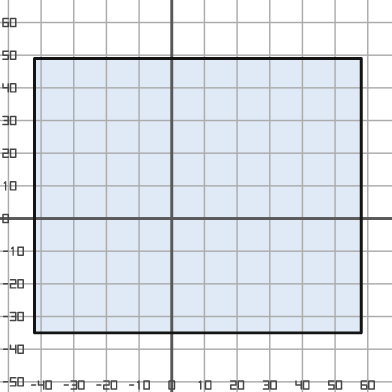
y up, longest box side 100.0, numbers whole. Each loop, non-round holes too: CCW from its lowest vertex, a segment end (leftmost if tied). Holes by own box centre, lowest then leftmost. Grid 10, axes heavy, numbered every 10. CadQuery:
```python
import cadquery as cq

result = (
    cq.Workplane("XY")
    .moveTo(-42.0, -35.0)
    .lineTo(58.0, -35.0)
    .lineTo(58.0, 49.0)
    .lineTo(-42.0, 49.0)
    .close()
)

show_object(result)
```